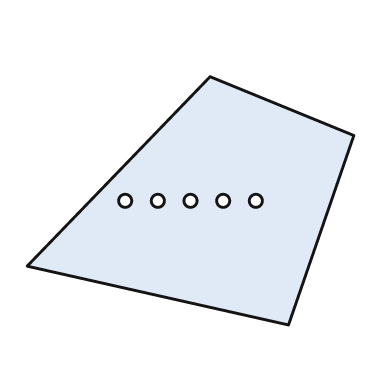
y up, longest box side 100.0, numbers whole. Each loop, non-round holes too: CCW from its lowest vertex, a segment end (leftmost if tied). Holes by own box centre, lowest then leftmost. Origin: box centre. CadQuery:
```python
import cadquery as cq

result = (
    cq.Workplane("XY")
    .moveTo(30.0, -38.0)
    .lineTo(50.0, 20.0)
    .lineTo(6.0, 38.0)
    .lineTo(-50.0, -20.0)
    .close()
    .moveTo(-20.0, 0.0)
    .circle(2.0)
    .moveTo(-10.0, 0.0)
    .circle(2.0)
    .moveTo(0.0, 0.0)
    .circle(2.0)
    .moveTo(10.0, 0.0)
    .circle(2.0)
    .moveTo(20.0, 0.0)
    .circle(2.0)
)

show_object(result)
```